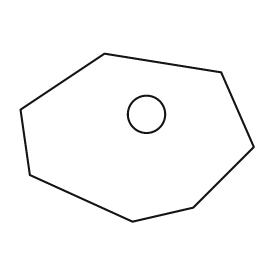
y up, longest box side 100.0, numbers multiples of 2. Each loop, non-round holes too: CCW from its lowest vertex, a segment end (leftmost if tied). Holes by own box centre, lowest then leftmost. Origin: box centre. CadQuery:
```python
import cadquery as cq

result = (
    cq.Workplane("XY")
    .moveTo(-2.0, -36.0)
    .lineTo(24.0, -30.0)
    .lineTo(50.0, -4.0)
    .lineTo(36.0, 28.0)
    .lineTo(-14.0, 36.0)
    .lineTo(-50.0, 12.0)
    .lineTo(-46.0, -16.0)
    .close()
    .moveTo(4.0, 10.0)
    .circle(8.0)
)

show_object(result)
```